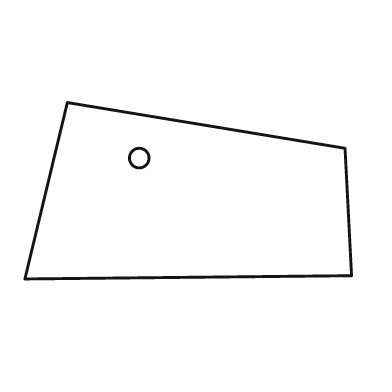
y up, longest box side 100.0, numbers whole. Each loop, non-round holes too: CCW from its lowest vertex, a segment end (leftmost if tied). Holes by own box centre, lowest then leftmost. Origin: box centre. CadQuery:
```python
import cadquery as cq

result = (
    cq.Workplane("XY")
    .moveTo(-50.0, -27.0)
    .lineTo(50.0, -26.0)
    .lineTo(48.0, 13.0)
    .lineTo(-37.0, 27.0)
    .close()
    .moveTo(-15.0, 10.0)
    .circle(3.0)
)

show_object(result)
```